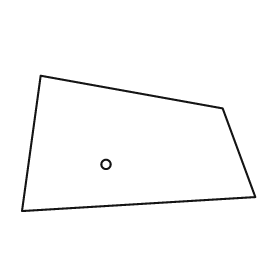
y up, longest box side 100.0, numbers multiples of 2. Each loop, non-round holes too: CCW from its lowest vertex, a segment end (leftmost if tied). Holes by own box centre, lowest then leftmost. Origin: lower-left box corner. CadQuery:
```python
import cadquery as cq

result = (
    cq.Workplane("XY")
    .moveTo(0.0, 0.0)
    .lineTo(100.0, 6.0)
    .lineTo(86.0, 44.0)
    .lineTo(8.0, 58.0)
    .close()
    .moveTo(36.0, 20.0)
    .circle(2.0)
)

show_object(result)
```